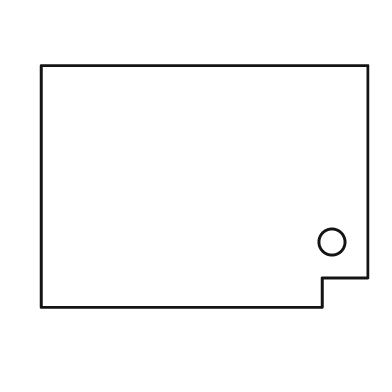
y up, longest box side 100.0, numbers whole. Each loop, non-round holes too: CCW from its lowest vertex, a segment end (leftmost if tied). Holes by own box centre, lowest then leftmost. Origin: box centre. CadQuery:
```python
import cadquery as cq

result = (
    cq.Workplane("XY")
    .moveTo(-50.0, -37.0)
    .lineTo(36.0, -37.0)
    .lineTo(36.0, -28.0)
    .lineTo(50.0, -28.0)
    .lineTo(50.0, 37.0)
    .lineTo(-50.0, 37.0)
    .close()
    .moveTo(39.0, -17.0)
    .circle(4.0)
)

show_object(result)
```